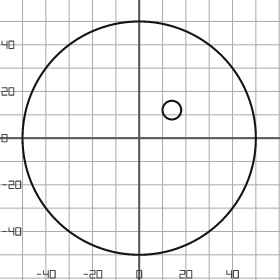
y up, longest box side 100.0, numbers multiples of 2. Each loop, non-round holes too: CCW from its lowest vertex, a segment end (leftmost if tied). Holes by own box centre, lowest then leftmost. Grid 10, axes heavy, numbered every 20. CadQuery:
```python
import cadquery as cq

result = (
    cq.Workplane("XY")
    .moveTo(0.0, 0.0)
    .circle(50.0)
    .moveTo(14.0, 12.0)
    .circle(4.0)
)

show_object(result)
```